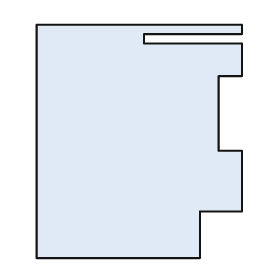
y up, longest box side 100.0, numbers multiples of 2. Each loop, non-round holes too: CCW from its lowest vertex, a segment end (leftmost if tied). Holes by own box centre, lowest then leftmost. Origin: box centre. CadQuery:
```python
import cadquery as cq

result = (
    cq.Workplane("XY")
    .moveTo(-44.0, -50.0)
    .lineTo(26.0, -50.0)
    .lineTo(26.0, -30.0)
    .lineTo(44.0, -30.0)
    .lineTo(44.0, -4.0)
    .lineTo(34.0, -4.0)
    .lineTo(34.0, 28.0)
    .lineTo(44.0, 28.0)
    .lineTo(44.0, 42.0)
    .lineTo(2.0, 42.0)
    .lineTo(2.0, 46.0)
    .lineTo(44.0, 46.0)
    .lineTo(44.0, 50.0)
    .lineTo(-44.0, 50.0)
    .close()
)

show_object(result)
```